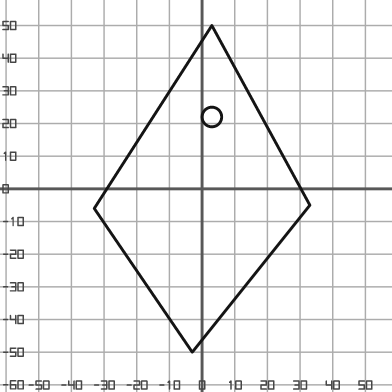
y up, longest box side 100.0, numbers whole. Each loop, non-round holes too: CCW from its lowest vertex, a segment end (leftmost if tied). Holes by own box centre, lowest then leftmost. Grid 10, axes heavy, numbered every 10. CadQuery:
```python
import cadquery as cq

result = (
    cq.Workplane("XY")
    .moveTo(-3.0, -50.0)
    .lineTo(33.0, -5.0)
    .lineTo(3.0, 50.0)
    .lineTo(-33.0, -6.0)
    .close()
    .moveTo(3.0, 22.0)
    .circle(3.0)
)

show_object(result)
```